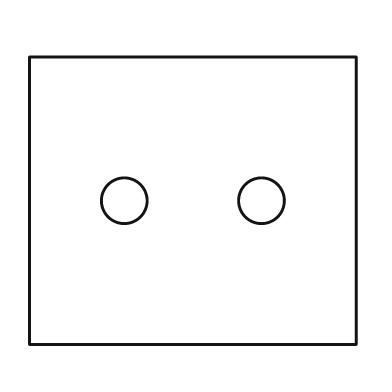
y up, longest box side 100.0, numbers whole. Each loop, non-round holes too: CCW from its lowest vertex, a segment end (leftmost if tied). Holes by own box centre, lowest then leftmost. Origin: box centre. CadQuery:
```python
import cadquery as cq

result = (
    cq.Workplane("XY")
    .moveTo(-50.0, -44.0)
    .lineTo(50.0, -44.0)
    .lineTo(50.0, 44.0)
    .lineTo(-50.0, 44.0)
    .close()
    .moveTo(-21.0, 0.0)
    .circle(7.0)
    .moveTo(21.0, 0.0)
    .circle(7.0)
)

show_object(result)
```